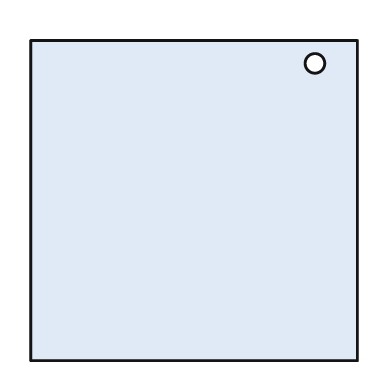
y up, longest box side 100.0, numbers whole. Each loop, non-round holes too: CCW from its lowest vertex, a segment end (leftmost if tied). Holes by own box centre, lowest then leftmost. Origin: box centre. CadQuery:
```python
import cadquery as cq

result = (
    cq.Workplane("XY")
    .moveTo(-50.0, -49.0)
    .lineTo(50.0, -49.0)
    .lineTo(50.0, 49.0)
    .lineTo(-50.0, 49.0)
    .close()
    .moveTo(37.0, 42.0)
    .circle(3.0)
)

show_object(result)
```